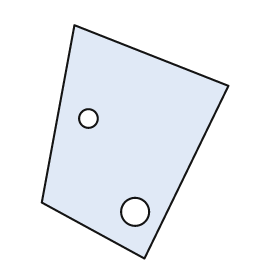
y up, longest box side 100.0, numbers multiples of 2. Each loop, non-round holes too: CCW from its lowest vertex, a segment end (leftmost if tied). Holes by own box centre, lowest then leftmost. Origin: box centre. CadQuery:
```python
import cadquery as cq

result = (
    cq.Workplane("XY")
    .moveTo(4.0, -50.0)
    .lineTo(40.0, 24.0)
    .lineTo(-26.0, 50.0)
    .lineTo(-40.0, -26.0)
    .close()
    .moveTo(0.0, -30.0)
    .circle(6.0)
    .moveTo(-20.0, 10.0)
    .circle(4.0)
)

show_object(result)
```